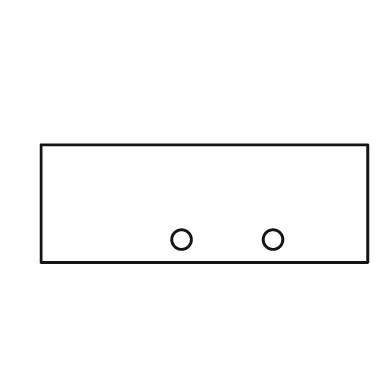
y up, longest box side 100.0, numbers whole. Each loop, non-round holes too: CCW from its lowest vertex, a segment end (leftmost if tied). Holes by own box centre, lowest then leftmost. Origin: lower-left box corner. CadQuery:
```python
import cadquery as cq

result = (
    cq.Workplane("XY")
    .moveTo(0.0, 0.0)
    .lineTo(100.0, 0.0)
    .lineTo(100.0, 36.0)
    .lineTo(0.0, 36.0)
    .close()
    .moveTo(43.0, 7.0)
    .circle(3.0)
    .moveTo(71.0, 7.0)
    .circle(3.0)
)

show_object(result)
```